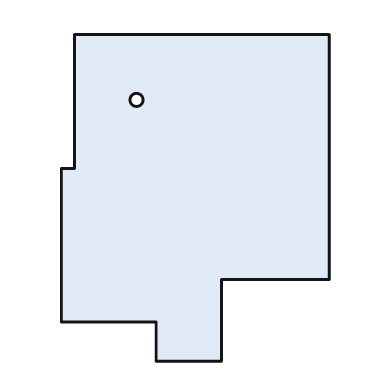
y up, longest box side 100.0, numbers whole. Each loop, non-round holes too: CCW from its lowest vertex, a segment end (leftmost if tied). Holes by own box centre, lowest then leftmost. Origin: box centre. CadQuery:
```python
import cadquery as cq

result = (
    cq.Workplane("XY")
    .moveTo(-12.0, -50.0)
    .lineTo(8.0, -50.0)
    .lineTo(8.0, -25.0)
    .lineTo(41.0, -25.0)
    .lineTo(41.0, 50.0)
    .lineTo(-37.0, 50.0)
    .lineTo(-37.0, 9.0)
    .lineTo(-41.0, 9.0)
    .lineTo(-41.0, -38.0)
    .lineTo(-12.0, -38.0)
    .close()
    .moveTo(-18.0, 30.0)
    .circle(2.0)
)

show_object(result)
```